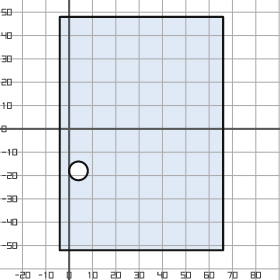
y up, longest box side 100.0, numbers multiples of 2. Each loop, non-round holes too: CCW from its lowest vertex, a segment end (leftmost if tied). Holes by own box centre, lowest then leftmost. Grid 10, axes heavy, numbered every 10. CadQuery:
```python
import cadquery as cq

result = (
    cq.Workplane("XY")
    .moveTo(-4.0, -52.0)
    .lineTo(66.0, -52.0)
    .lineTo(66.0, 48.0)
    .lineTo(-4.0, 48.0)
    .close()
    .moveTo(4.0, -18.0)
    .circle(4.0)
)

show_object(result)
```